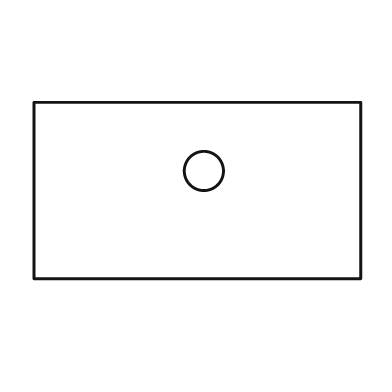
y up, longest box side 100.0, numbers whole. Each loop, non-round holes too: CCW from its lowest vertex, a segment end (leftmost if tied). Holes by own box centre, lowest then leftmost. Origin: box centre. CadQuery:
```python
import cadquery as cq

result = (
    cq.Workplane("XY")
    .moveTo(-50.0, -27.0)
    .lineTo(50.0, -27.0)
    .lineTo(50.0, 27.0)
    .lineTo(-50.0, 27.0)
    .close()
    .moveTo(2.0, 6.0)
    .circle(6.0)
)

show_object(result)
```